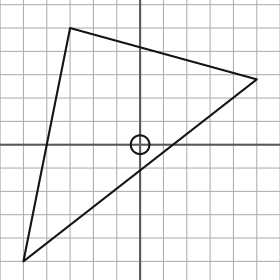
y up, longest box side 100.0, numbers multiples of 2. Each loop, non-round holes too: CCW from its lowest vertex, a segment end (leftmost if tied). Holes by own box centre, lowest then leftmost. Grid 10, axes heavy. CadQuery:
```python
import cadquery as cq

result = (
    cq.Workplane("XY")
    .moveTo(-50.0, -50.0)
    .lineTo(50.0, 28.0)
    .lineTo(-30.0, 50.0)
    .close()
    .moveTo(0.0, 0.0)
    .circle(4.0)
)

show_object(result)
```